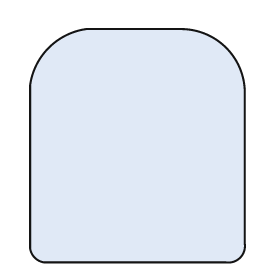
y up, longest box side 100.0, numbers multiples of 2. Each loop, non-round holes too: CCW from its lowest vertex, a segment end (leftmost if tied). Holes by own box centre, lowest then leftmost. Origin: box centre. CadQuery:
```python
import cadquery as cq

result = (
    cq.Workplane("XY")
    .moveTo(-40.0, -50.0)
    .lineTo(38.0, -50.0)
    .threePointArc((44.0, -48.0), (46.0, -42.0))
    .lineTo(46.0, 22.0)
    .threePointArc((38.0, 42.0), (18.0, 50.0))
    .lineTo(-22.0, 50.0)
    .threePointArc((-38.0, 42.0), (-46.0, 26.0))
    .lineTo(-46.0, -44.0)
    .threePointArc((-44.0, -48.0), (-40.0, -50.0))
    .close()
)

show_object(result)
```